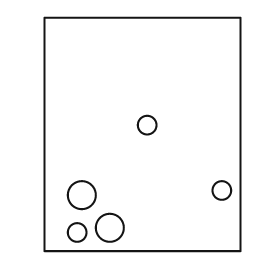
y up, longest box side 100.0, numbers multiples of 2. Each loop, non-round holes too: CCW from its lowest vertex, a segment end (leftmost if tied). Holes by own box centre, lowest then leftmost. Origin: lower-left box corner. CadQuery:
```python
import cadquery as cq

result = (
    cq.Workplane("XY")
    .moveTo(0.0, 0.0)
    .lineTo(84.0, 0.0)
    .lineTo(84.0, 100.0)
    .lineTo(0.0, 100.0)
    .close()
    .moveTo(14.0, 8.0)
    .circle(4.0)
    .moveTo(28.0, 10.0)
    .circle(6.0)
    .moveTo(16.0, 24.0)
    .circle(6.0)
    .moveTo(76.0, 26.0)
    .circle(4.0)
    .moveTo(44.0, 54.0)
    .circle(4.0)
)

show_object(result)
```